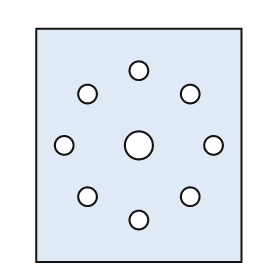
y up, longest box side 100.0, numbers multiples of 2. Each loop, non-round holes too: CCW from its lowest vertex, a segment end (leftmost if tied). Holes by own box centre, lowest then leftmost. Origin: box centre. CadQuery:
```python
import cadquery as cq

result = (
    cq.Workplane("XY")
    .moveTo(-44.0, -50.0)
    .lineTo(44.0, -50.0)
    .lineTo(44.0, 50.0)
    .lineTo(-44.0, 50.0)
    .close()
    .moveTo(0.0, -32.0)
    .circle(4.0)
    .moveTo(-22.0, -22.0)
    .circle(4.0)
    .moveTo(22.0, -22.0)
    .circle(4.0)
    .moveTo(-32.0, 0.0)
    .circle(4.0)
    .moveTo(0.0, 0.0)
    .circle(6.0)
    .moveTo(32.0, 0.0)
    .circle(4.0)
    .moveTo(-22.0, 22.0)
    .circle(4.0)
    .moveTo(22.0, 22.0)
    .circle(4.0)
    .moveTo(0.0, 32.0)
    .circle(4.0)
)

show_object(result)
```